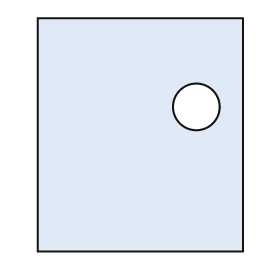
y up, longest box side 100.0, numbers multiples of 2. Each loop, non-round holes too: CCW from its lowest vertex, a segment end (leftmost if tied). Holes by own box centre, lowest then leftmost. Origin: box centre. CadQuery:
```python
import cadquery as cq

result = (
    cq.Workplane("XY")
    .moveTo(-44.0, -50.0)
    .lineTo(44.0, -50.0)
    .lineTo(44.0, 50.0)
    .lineTo(-44.0, 50.0)
    .close()
    .moveTo(24.0, 12.0)
    .circle(10.0)
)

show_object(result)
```